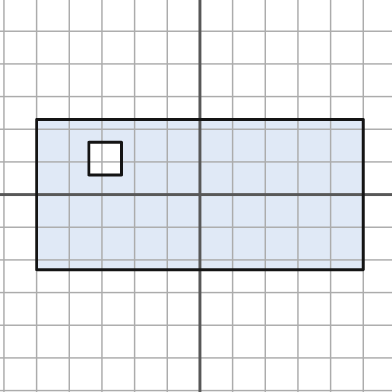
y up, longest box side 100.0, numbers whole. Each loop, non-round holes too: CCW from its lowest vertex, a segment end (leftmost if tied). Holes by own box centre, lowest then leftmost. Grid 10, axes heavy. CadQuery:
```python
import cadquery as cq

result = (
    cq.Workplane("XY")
    .moveTo(-50.0, -23.0)
    .lineTo(50.0, -23.0)
    .lineTo(50.0, 23.0)
    .lineTo(-50.0, 23.0)
    .close()
    .moveTo(-34.0, 6.0)
    .lineTo(-24.0, 6.0)
    .lineTo(-24.0, 16.0)
    .lineTo(-34.0, 16.0)
    .close()
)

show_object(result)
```